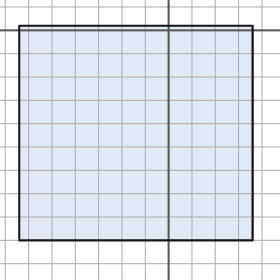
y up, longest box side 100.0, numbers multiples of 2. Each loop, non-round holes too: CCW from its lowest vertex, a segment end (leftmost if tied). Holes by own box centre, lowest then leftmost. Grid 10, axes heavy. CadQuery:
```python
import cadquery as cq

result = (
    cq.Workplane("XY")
    .moveTo(-64.0, -90.0)
    .lineTo(36.0, -90.0)
    .lineTo(36.0, 2.0)
    .lineTo(-64.0, 2.0)
    .close()
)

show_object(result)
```